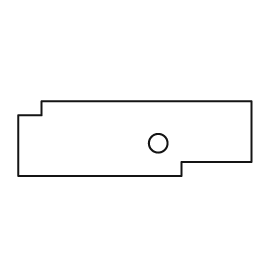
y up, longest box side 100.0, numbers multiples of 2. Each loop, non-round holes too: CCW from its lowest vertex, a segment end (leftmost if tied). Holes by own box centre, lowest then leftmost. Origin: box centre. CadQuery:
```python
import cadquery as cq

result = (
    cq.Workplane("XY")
    .moveTo(-50.0, -16.0)
    .lineTo(20.0, -16.0)
    .lineTo(20.0, -10.0)
    .lineTo(50.0, -10.0)
    .lineTo(50.0, 16.0)
    .lineTo(-40.0, 16.0)
    .lineTo(-40.0, 10.0)
    .lineTo(-50.0, 10.0)
    .close()
    .moveTo(10.0, -2.0)
    .circle(4.0)
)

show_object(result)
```